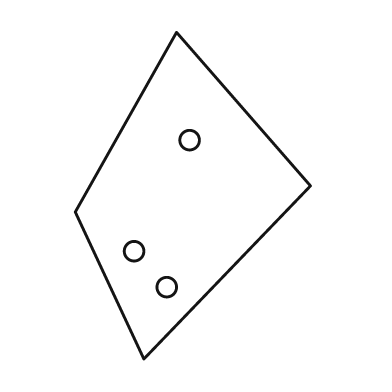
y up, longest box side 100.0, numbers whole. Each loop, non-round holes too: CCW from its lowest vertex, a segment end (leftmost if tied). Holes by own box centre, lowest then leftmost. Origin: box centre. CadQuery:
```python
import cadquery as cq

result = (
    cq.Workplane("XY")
    .moveTo(-15.0, -50.0)
    .lineTo(36.0, 3.0)
    .lineTo(-5.0, 50.0)
    .lineTo(-36.0, -5.0)
    .close()
    .moveTo(-8.0, -28.0)
    .circle(3.0)
    .moveTo(-18.0, -17.0)
    .circle(3.0)
    .moveTo(-1.0, 17.0)
    .circle(3.0)
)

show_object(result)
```